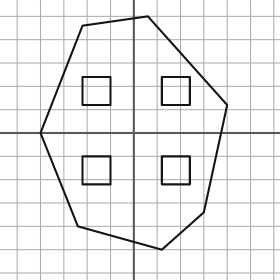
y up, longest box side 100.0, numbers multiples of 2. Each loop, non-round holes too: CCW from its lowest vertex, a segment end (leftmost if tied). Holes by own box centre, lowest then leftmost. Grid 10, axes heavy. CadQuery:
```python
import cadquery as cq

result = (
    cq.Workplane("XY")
    .moveTo(12.0, -50.0)
    .lineTo(30.0, -34.0)
    .lineTo(40.0, 12.0)
    .lineTo(6.0, 50.0)
    .lineTo(-22.0, 46.0)
    .lineTo(-40.0, 0.0)
    .lineTo(-24.0, -40.0)
    .close()
    .moveTo(-22.0, -22.0)
    .lineTo(-10.0, -22.0)
    .lineTo(-10.0, -10.0)
    .lineTo(-22.0, -10.0)
    .close()
    .moveTo(12.0, -22.0)
    .lineTo(24.0, -22.0)
    .lineTo(24.0, -10.0)
    .lineTo(12.0, -10.0)
    .close()
    .moveTo(-22.0, 12.0)
    .lineTo(-10.0, 12.0)
    .lineTo(-10.0, 24.0)
    .lineTo(-22.0, 24.0)
    .close()
    .moveTo(12.0, 12.0)
    .lineTo(24.0, 12.0)
    .lineTo(24.0, 24.0)
    .lineTo(12.0, 24.0)
    .close()
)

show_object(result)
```